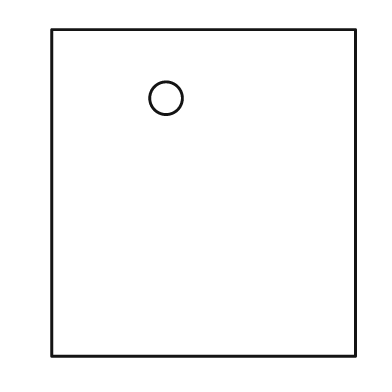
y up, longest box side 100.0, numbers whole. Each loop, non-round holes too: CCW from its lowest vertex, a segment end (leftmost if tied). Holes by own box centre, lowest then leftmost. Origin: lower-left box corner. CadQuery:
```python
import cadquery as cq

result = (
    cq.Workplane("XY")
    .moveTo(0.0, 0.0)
    .lineTo(93.0, 0.0)
    .lineTo(93.0, 100.0)
    .lineTo(0.0, 100.0)
    .close()
    .moveTo(35.0, 79.0)
    .circle(5.0)
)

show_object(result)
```